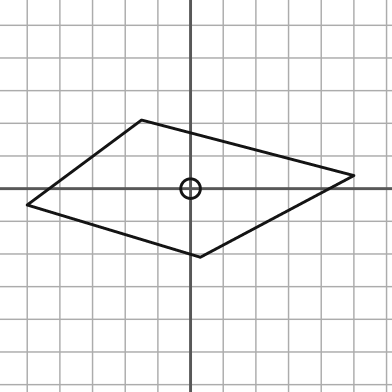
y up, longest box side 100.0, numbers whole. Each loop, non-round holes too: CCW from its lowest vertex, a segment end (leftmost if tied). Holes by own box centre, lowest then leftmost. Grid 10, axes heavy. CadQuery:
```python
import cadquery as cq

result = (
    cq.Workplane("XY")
    .moveTo(3.0, -21.0)
    .lineTo(50.0, 4.0)
    .lineTo(-15.0, 21.0)
    .lineTo(-50.0, -5.0)
    .close()
    .moveTo(0.0, 0.0)
    .circle(3.0)
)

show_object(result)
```